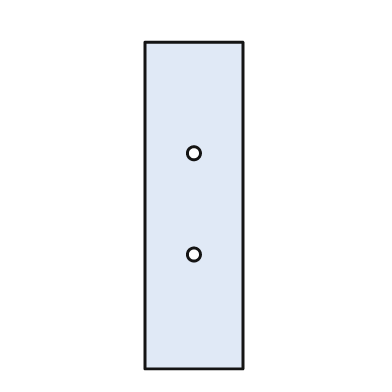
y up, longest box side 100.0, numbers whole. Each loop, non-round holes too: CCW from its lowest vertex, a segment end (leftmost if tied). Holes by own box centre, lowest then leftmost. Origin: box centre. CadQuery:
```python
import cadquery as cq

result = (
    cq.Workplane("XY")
    .moveTo(-15.0, -50.0)
    .lineTo(15.0, -50.0)
    .lineTo(15.0, 50.0)
    .lineTo(-15.0, 50.0)
    .close()
    .moveTo(0.0, -15.0)
    .circle(2.0)
    .moveTo(0.0, 16.0)
    .circle(2.0)
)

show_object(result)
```